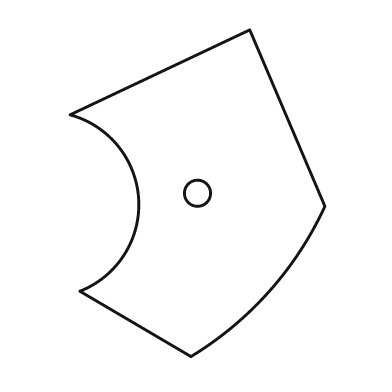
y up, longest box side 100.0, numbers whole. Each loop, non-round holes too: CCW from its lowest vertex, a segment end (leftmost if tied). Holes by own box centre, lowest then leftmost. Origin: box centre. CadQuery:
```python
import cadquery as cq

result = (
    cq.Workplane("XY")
    .moveTo(-2.0, -50.0)
    .threePointArc((22.0, -30.0), (39.0, -4.0))
    .lineTo(16.0, 50.0)
    .lineTo(-39.0, 24.0)
    .threePointArc((-18.0, -2.0), (-36.0, -30.0))
    .close()
    .moveTo(0.0, 0.0)
    .circle(4.0)
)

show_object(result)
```